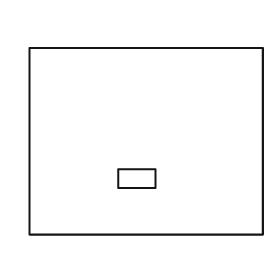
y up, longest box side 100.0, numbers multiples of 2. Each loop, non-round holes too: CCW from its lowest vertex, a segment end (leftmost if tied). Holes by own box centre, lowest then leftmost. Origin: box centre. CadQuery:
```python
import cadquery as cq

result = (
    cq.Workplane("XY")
    .moveTo(-50.0, -40.0)
    .lineTo(50.0, -40.0)
    .lineTo(50.0, 40.0)
    .lineTo(-50.0, 40.0)
    .close()
    .moveTo(-12.0, -20.0)
    .lineTo(4.0, -20.0)
    .lineTo(4.0, -12.0)
    .lineTo(-12.0, -12.0)
    .close()
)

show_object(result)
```